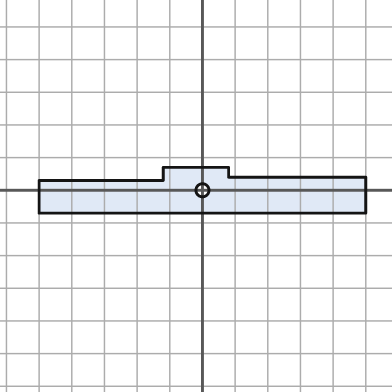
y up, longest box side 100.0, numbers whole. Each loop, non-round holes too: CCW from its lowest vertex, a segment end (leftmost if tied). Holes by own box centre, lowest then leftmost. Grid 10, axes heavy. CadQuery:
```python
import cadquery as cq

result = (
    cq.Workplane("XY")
    .moveTo(-50.0, -7.0)
    .lineTo(50.0, -7.0)
    .lineTo(50.0, 4.0)
    .lineTo(8.0, 4.0)
    .lineTo(8.0, 7.0)
    .lineTo(-12.0, 7.0)
    .lineTo(-12.0, 3.0)
    .lineTo(-50.0, 3.0)
    .close()
    .moveTo(0.0, 0.0)
    .circle(2.0)
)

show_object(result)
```